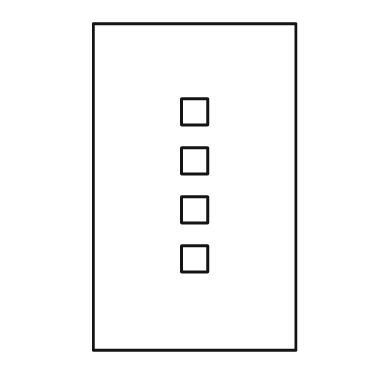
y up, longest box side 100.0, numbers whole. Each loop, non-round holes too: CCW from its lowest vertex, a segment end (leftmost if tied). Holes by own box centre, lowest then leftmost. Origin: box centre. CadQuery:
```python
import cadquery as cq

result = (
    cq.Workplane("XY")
    .moveTo(-31.0, -50.0)
    .lineTo(31.0, -50.0)
    .lineTo(31.0, 50.0)
    .lineTo(-31.0, 50.0)
    .close()
    .moveTo(-4.0, -26.0)
    .lineTo(4.0, -26.0)
    .lineTo(4.0, -18.0)
    .lineTo(-4.0, -18.0)
    .close()
    .moveTo(-4.0, -11.0)
    .lineTo(4.0, -11.0)
    .lineTo(4.0, -3.0)
    .lineTo(-4.0, -3.0)
    .close()
    .moveTo(-4.0, 4.0)
    .lineTo(4.0, 4.0)
    .lineTo(4.0, 12.0)
    .lineTo(-4.0, 12.0)
    .close()
    .moveTo(-4.0, 19.0)
    .lineTo(4.0, 19.0)
    .lineTo(4.0, 27.0)
    .lineTo(-4.0, 27.0)
    .close()
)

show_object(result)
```